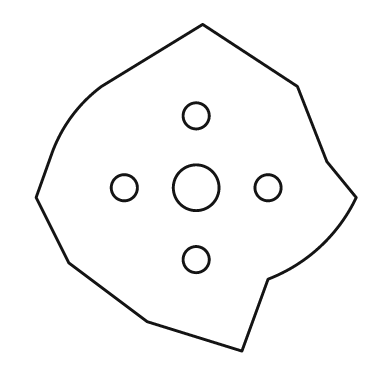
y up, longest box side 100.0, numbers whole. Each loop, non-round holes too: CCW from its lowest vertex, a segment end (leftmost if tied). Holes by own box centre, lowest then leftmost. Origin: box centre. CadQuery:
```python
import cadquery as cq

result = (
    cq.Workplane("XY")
    .moveTo(14.0, -50.0)
    .lineTo(22.0, -28.0)
    .threePointArc((38.0, -18.0), (49.0, -3.0))
    .lineTo(40.0, 8.0)
    .lineTo(31.0, 31.0)
    .lineTo(2.0, 50.0)
    .lineTo(-29.0, 31.0)
    .threePointArc((-38.0, 22.0), (-44.0, 11.0))
    .lineTo(-49.0, -3.0)
    .lineTo(-39.0, -23.0)
    .lineTo(-15.0, -41.0)
    .close()
    .moveTo(0.0, -22.0)
    .circle(4.0)
    .moveTo(-22.0, 0.0)
    .circle(4.0)
    .moveTo(0.0, 0.0)
    .circle(7.0)
    .moveTo(22.0, 0.0)
    .circle(4.0)
    .moveTo(0.0, 22.0)
    .circle(4.0)
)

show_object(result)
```